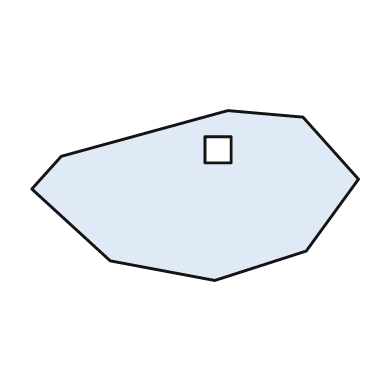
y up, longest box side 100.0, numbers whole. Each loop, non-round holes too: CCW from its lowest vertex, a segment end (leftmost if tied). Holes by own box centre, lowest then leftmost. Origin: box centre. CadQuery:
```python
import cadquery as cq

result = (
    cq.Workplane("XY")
    .moveTo(6.0, -26.0)
    .lineTo(34.0, -17.0)
    .lineTo(50.0, 5.0)
    .lineTo(33.0, 24.0)
    .lineTo(10.0, 26.0)
    .lineTo(-41.0, 12.0)
    .lineTo(-50.0, 2.0)
    .lineTo(-26.0, -20.0)
    .close()
    .moveTo(3.0, 10.0)
    .lineTo(11.0, 10.0)
    .lineTo(11.0, 18.0)
    .lineTo(3.0, 18.0)
    .close()
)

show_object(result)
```